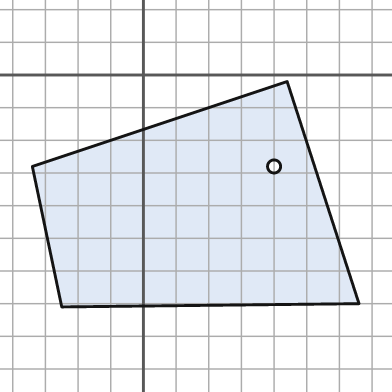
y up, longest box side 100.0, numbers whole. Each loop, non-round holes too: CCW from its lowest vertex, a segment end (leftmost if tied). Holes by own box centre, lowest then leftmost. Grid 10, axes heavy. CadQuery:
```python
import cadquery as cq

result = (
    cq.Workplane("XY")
    .moveTo(-25.0, -71.0)
    .lineTo(66.0, -70.0)
    .lineTo(44.0, -2.0)
    .lineTo(-34.0, -28.0)
    .close()
    .moveTo(40.0, -28.0)
    .circle(2.0)
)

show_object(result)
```